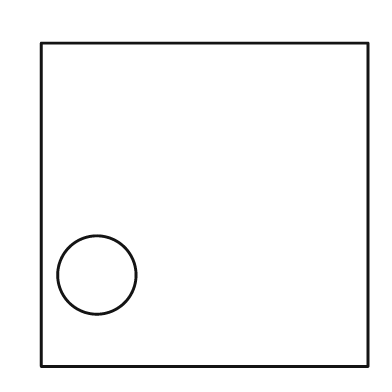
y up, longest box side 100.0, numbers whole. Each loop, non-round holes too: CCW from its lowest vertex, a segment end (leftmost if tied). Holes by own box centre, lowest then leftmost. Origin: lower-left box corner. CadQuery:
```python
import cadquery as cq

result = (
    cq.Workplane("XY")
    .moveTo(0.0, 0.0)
    .lineTo(100.0, 0.0)
    .lineTo(100.0, 99.0)
    .lineTo(0.0, 99.0)
    .close()
    .moveTo(17.0, 28.0)
    .circle(12.0)
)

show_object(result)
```